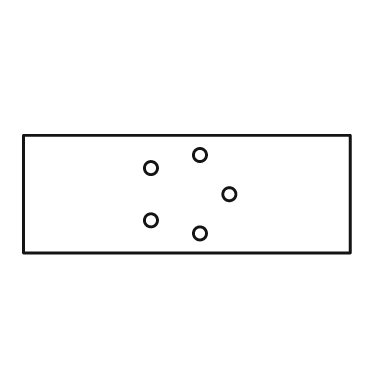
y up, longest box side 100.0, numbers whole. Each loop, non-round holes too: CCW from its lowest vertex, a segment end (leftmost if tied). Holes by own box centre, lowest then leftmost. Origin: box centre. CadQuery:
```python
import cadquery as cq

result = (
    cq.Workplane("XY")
    .moveTo(-50.0, -18.0)
    .lineTo(50.0, -18.0)
    .lineTo(50.0, 18.0)
    .lineTo(-50.0, 18.0)
    .close()
    .moveTo(4.0, -12.0)
    .circle(2.0)
    .moveTo(-11.0, -8.0)
    .circle(2.0)
    .moveTo(13.0, 0.0)
    .circle(2.0)
    .moveTo(-11.0, 8.0)
    .circle(2.0)
    .moveTo(4.0, 12.0)
    .circle(2.0)
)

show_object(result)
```